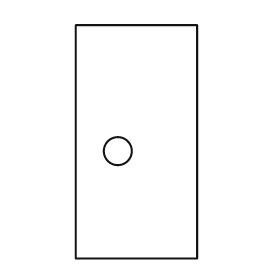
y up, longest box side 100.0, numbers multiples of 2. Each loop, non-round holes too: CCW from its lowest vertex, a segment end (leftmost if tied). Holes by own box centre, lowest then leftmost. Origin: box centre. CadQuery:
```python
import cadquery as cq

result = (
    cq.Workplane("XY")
    .moveTo(-26.0, -50.0)
    .lineTo(26.0, -50.0)
    .lineTo(26.0, 50.0)
    .lineTo(-26.0, 50.0)
    .close()
    .moveTo(-8.0, -4.0)
    .circle(6.0)
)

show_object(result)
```